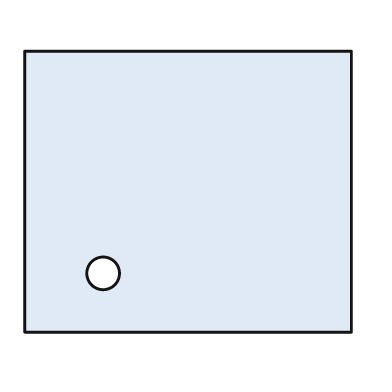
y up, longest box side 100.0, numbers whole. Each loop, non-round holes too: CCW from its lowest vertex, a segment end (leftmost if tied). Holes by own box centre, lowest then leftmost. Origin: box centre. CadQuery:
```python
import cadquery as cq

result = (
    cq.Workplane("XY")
    .moveTo(-50.0, -43.0)
    .lineTo(50.0, -43.0)
    .lineTo(50.0, 43.0)
    .lineTo(-50.0, 43.0)
    .close()
    .moveTo(-26.0, -25.0)
    .circle(5.0)
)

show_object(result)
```